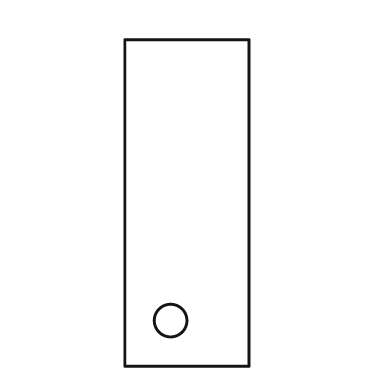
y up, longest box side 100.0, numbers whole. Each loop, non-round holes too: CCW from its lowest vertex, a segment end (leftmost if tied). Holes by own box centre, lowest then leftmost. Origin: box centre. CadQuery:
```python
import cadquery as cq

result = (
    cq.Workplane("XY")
    .moveTo(-19.0, -50.0)
    .lineTo(19.0, -50.0)
    .lineTo(19.0, 50.0)
    .lineTo(-19.0, 50.0)
    .close()
    .moveTo(-5.0, -36.0)
    .circle(5.0)
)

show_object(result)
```